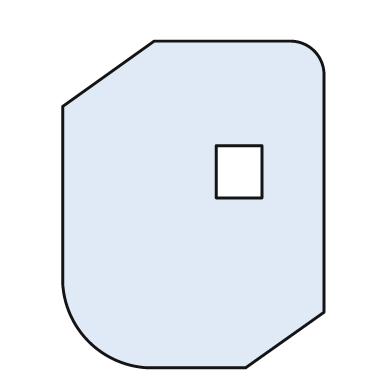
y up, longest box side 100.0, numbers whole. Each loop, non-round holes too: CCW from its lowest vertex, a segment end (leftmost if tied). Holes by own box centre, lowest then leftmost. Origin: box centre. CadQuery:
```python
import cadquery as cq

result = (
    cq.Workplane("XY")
    .moveTo(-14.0, -50.0)
    .lineTo(16.0, -50.0)
    .lineTo(40.0, -33.0)
    .lineTo(40.0, 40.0)
    .threePointArc((37.0, 47.0), (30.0, 50.0))
    .lineTo(-12.0, 50.0)
    .lineTo(-40.0, 30.0)
    .lineTo(-40.0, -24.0)
    .threePointArc((-32.0, -42.0), (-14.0, -50.0))
    .close()
    .moveTo(7.0, 2.0)
    .lineTo(21.0, 2.0)
    .lineTo(21.0, 18.0)
    .lineTo(7.0, 18.0)
    .close()
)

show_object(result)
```